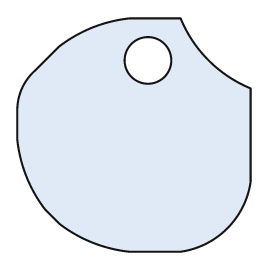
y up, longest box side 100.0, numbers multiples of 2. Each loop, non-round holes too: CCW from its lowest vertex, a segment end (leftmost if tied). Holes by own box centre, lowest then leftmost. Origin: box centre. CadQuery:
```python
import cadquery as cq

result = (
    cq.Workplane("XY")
    .moveTo(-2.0, -50.0)
    .lineTo(20.0, -50.0)
    .threePointArc((40.0, -40.0), (50.0, -20.0))
    .lineTo(50.0, 20.0)
    .threePointArc((32.0, 32.0), (20.0, 50.0))
    .lineTo(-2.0, 50.0)
    .threePointArc((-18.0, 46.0), (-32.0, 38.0))
    .lineTo(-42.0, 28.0)
    .threePointArc((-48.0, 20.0), (-50.0, 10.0))
    .lineTo(-50.0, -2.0)
    .threePointArc((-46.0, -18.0), (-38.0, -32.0))
    .lineTo(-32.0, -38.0)
    .threePointArc((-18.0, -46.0), (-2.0, -50.0))
    .close()
    .moveTo(6.0, 32.0)
    .circle(10.0)
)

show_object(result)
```